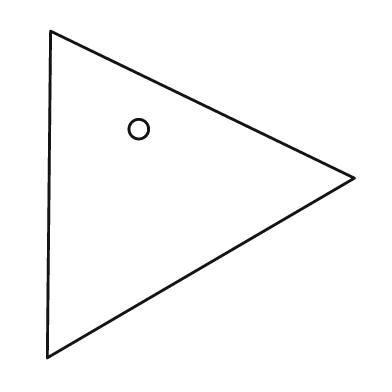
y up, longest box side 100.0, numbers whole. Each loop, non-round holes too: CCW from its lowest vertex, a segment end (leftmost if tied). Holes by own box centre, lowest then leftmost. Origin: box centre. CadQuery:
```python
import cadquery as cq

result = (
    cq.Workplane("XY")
    .moveTo(-47.0, -50.0)
    .lineTo(47.0, 5.0)
    .lineTo(-46.0, 50.0)
    .close()
    .moveTo(-19.0, 20.0)
    .circle(3.0)
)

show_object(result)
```